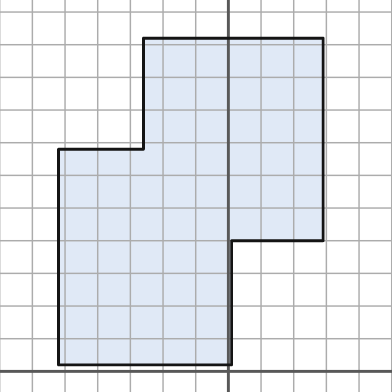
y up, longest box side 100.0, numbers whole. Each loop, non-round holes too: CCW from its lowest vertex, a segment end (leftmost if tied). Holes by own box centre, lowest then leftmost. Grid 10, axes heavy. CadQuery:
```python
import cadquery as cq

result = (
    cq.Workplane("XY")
    .moveTo(-52.0, 2.0)
    .lineTo(1.0, 2.0)
    .lineTo(1.0, 40.0)
    .lineTo(29.0, 40.0)
    .lineTo(29.0, 102.0)
    .lineTo(-26.0, 102.0)
    .lineTo(-26.0, 68.0)
    .lineTo(-52.0, 68.0)
    .close()
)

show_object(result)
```